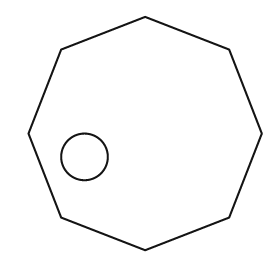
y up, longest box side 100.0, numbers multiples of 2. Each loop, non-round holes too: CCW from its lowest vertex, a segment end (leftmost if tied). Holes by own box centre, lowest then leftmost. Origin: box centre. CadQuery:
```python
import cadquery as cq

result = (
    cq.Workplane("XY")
    .moveTo(0.0, -50.0)
    .lineTo(36.0, -36.0)
    .lineTo(50.0, 0.0)
    .lineTo(36.0, 36.0)
    .lineTo(0.0, 50.0)
    .lineTo(-36.0, 36.0)
    .lineTo(-50.0, 0.0)
    .lineTo(-36.0, -36.0)
    .close()
    .moveTo(-26.0, -10.0)
    .circle(10.0)
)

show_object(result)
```